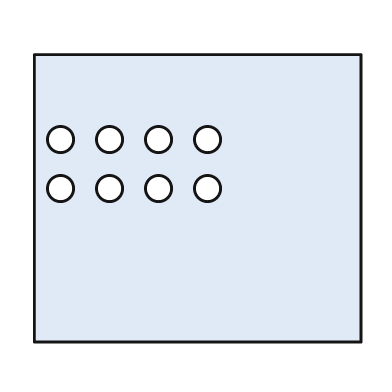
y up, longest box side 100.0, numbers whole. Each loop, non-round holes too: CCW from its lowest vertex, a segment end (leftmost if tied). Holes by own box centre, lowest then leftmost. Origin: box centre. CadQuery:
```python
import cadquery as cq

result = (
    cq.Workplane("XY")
    .moveTo(-50.0, -44.0)
    .lineTo(50.0, -44.0)
    .lineTo(50.0, 44.0)
    .lineTo(-50.0, 44.0)
    .close()
    .moveTo(-42.0, 3.0)
    .circle(4.0)
    .moveTo(-27.0, 3.0)
    .circle(4.0)
    .moveTo(-12.0, 3.0)
    .circle(4.0)
    .moveTo(3.0, 3.0)
    .circle(4.0)
    .moveTo(-42.0, 18.0)
    .circle(4.0)
    .moveTo(-27.0, 18.0)
    .circle(4.0)
    .moveTo(-12.0, 18.0)
    .circle(4.0)
    .moveTo(3.0, 18.0)
    .circle(4.0)
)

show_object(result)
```